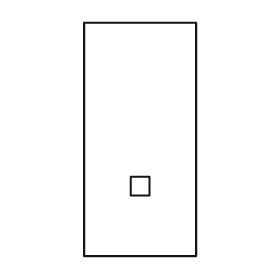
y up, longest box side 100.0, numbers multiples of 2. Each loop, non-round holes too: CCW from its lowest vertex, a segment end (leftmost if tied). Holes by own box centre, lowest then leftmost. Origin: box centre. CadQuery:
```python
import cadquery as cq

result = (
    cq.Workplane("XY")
    .moveTo(-24.0, -50.0)
    .lineTo(24.0, -50.0)
    .lineTo(24.0, 50.0)
    .lineTo(-24.0, 50.0)
    .close()
    .moveTo(-4.0, -24.0)
    .lineTo(4.0, -24.0)
    .lineTo(4.0, -16.0)
    .lineTo(-4.0, -16.0)
    .close()
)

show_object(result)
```